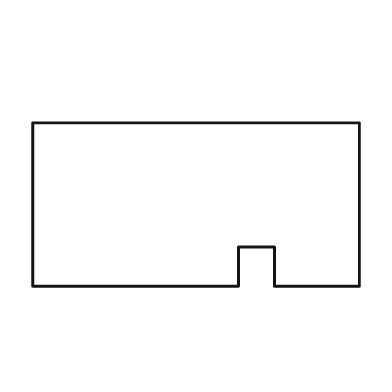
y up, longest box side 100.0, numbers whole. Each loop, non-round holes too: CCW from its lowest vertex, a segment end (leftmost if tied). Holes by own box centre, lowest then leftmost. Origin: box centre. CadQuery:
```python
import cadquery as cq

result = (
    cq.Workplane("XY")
    .moveTo(-50.0, -25.0)
    .lineTo(13.0, -25.0)
    .lineTo(13.0, -13.0)
    .lineTo(24.0, -13.0)
    .lineTo(24.0, -25.0)
    .lineTo(50.0, -25.0)
    .lineTo(50.0, 25.0)
    .lineTo(-50.0, 25.0)
    .close()
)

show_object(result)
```